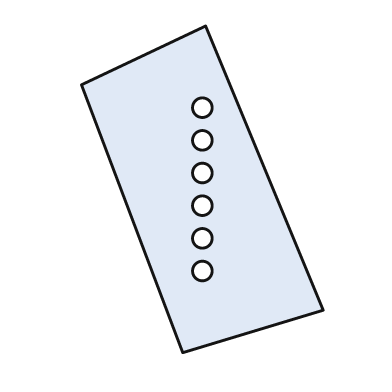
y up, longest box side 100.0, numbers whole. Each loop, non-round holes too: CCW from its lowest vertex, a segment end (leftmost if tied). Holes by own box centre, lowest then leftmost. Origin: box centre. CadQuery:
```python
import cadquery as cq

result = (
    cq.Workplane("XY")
    .moveTo(-6.0, -50.0)
    .lineTo(37.0, -37.0)
    .lineTo(1.0, 50.0)
    .lineTo(-37.0, 32.0)
    .close()
    .moveTo(0.0, -25.0)
    .circle(3.0)
    .moveTo(0.0, -15.0)
    .circle(3.0)
    .moveTo(0.0, -5.0)
    .circle(3.0)
    .moveTo(0.0, 5.0)
    .circle(3.0)
    .moveTo(0.0, 15.0)
    .circle(3.0)
    .moveTo(0.0, 25.0)
    .circle(3.0)
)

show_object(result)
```